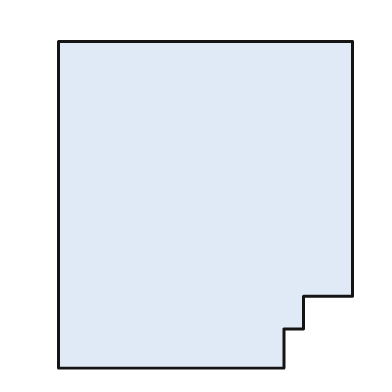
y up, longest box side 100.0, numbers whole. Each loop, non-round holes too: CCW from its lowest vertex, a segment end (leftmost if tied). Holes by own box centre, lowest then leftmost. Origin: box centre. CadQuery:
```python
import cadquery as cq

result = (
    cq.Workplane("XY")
    .moveTo(-45.0, -50.0)
    .lineTo(24.0, -50.0)
    .lineTo(24.0, -38.0)
    .lineTo(30.0, -38.0)
    .lineTo(30.0, -28.0)
    .lineTo(45.0, -28.0)
    .lineTo(45.0, 50.0)
    .lineTo(-45.0, 50.0)
    .close()
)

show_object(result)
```